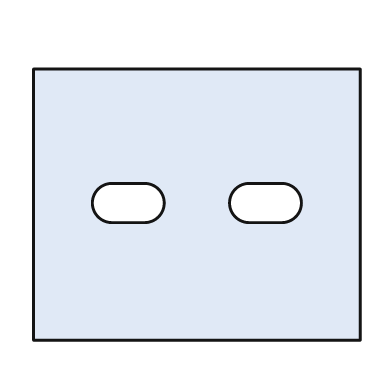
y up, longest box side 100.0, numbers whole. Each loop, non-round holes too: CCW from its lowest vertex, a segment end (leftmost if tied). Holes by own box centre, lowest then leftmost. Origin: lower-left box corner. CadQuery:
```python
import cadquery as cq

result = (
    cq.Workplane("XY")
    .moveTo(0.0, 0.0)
    .lineTo(100.0, 0.0)
    .lineTo(100.0, 83.0)
    .lineTo(0.0, 83.0)
    .close()
    .moveTo(24.0, 36.0)
    .lineTo(34.0, 36.0)
    .threePointArc((40.0, 42.0), (34.0, 48.0))
    .lineTo(24.0, 48.0)
    .threePointArc((18.0, 42.0), (24.0, 36.0))
    .close()
    .moveTo(66.0, 36.0)
    .lineTo(76.0, 36.0)
    .threePointArc((82.0, 42.0), (76.0, 48.0))
    .lineTo(66.0, 48.0)
    .threePointArc((60.0, 42.0), (66.0, 36.0))
    .close()
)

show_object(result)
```